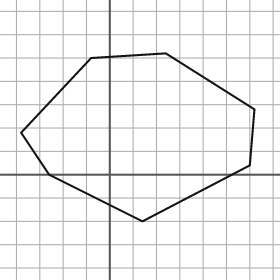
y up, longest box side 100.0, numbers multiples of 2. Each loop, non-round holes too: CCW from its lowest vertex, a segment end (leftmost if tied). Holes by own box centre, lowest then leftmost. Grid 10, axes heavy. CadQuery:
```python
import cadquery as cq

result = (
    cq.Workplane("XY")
    .moveTo(14.0, -20.0)
    .lineTo(60.0, 4.0)
    .lineTo(62.0, 28.0)
    .lineTo(24.0, 52.0)
    .lineTo(-8.0, 50.0)
    .lineTo(-38.0, 18.0)
    .lineTo(-26.0, 0.0)
    .close()
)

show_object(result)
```